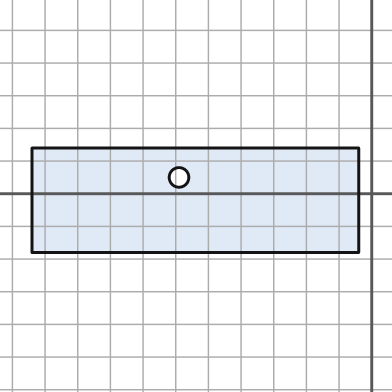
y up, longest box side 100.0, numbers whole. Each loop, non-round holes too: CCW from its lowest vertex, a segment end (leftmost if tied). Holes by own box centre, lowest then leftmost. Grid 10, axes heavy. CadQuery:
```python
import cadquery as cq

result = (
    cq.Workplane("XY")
    .moveTo(-104.0, -18.0)
    .lineTo(-4.0, -18.0)
    .lineTo(-4.0, 14.0)
    .lineTo(-104.0, 14.0)
    .close()
    .moveTo(-59.0, 5.0)
    .circle(3.0)
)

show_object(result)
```